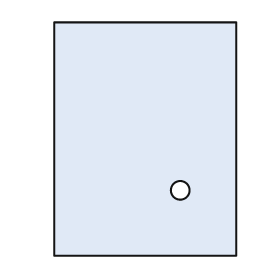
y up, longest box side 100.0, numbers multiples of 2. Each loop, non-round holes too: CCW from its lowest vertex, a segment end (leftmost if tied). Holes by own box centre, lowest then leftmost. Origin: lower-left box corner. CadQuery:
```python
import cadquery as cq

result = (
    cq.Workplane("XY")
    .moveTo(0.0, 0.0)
    .lineTo(78.0, 0.0)
    .lineTo(78.0, 100.0)
    .lineTo(0.0, 100.0)
    .close()
    .moveTo(54.0, 28.0)
    .circle(4.0)
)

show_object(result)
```